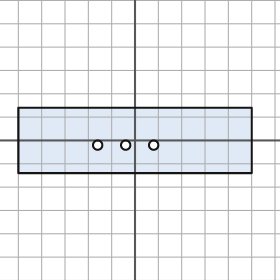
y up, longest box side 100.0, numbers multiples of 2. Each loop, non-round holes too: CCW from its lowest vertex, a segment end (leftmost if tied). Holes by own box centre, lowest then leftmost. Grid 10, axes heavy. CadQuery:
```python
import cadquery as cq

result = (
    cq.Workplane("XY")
    .moveTo(-50.0, -14.0)
    .lineTo(50.0, -14.0)
    .lineTo(50.0, 14.0)
    .lineTo(-50.0, 14.0)
    .close()
    .moveTo(-16.0, -2.0)
    .circle(2.0)
    .moveTo(-4.0, -2.0)
    .circle(2.0)
    .moveTo(8.0, -2.0)
    .circle(2.0)
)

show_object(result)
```